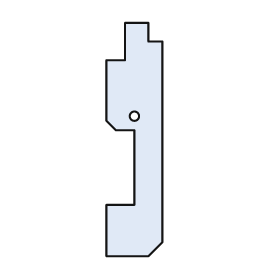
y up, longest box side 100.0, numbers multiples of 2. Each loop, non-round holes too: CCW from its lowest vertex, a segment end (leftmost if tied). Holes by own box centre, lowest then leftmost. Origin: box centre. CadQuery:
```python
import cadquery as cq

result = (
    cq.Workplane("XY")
    .moveTo(-12.0, -50.0)
    .lineTo(6.0, -50.0)
    .lineTo(12.0, -44.0)
    .lineTo(12.0, 42.0)
    .lineTo(6.0, 42.0)
    .lineTo(6.0, 50.0)
    .lineTo(-4.0, 50.0)
    .lineTo(-4.0, 34.0)
    .lineTo(-12.0, 34.0)
    .lineTo(-12.0, 8.0)
    .lineTo(-8.0, 4.0)
    .lineTo(0.0, 4.0)
    .lineTo(0.0, -28.0)
    .lineTo(-12.0, -28.0)
    .close()
    .moveTo(0.0, 10.0)
    .circle(2.0)
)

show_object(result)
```